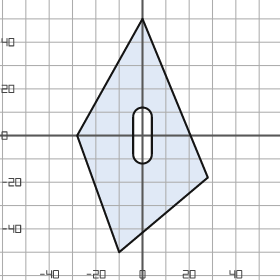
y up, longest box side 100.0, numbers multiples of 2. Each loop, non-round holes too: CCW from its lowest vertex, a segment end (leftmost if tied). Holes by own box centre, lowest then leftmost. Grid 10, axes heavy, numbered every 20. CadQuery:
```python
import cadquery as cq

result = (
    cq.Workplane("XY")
    .moveTo(-10.0, -50.0)
    .lineTo(28.0, -18.0)
    .lineTo(0.0, 50.0)
    .lineTo(-28.0, 0.0)
    .close()
    .moveTo(-4.0, -8.0)
    .threePointArc((0.0, -12.0), (4.0, -8.0))
    .lineTo(4.0, 8.0)
    .threePointArc((0.0, 12.0), (-4.0, 8.0))
    .close()
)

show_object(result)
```